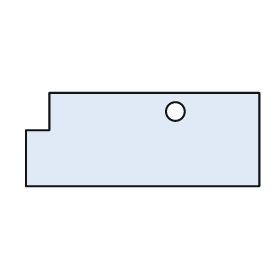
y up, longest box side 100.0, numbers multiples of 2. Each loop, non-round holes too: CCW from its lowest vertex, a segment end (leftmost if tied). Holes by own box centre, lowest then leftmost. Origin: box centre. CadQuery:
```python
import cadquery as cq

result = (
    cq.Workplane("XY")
    .moveTo(-50.0, -20.0)
    .lineTo(50.0, -20.0)
    .lineTo(50.0, 20.0)
    .lineTo(-40.0, 20.0)
    .lineTo(-40.0, 4.0)
    .lineTo(-50.0, 4.0)
    .close()
    .moveTo(14.0, 12.0)
    .circle(4.0)
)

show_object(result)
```